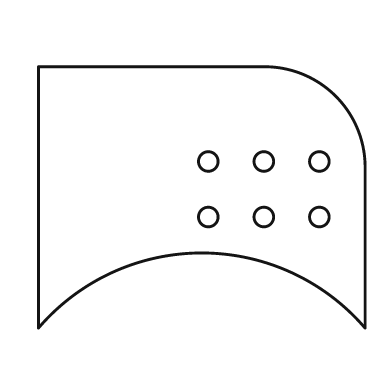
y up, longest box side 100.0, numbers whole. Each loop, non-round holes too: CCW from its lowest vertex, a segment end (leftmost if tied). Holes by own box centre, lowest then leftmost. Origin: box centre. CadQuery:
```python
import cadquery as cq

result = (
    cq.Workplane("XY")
    .moveTo(-50.0, -40.0)
    .threePointArc((0.0, -17.0), (50.0, -40.0))
    .lineTo(50.0, 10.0)
    .threePointArc((41.0, 31.0), (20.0, 40.0))
    .lineTo(-50.0, 40.0)
    .close()
    .moveTo(2.0, -6.0)
    .circle(3.0)
    .moveTo(19.0, -6.0)
    .circle(3.0)
    .moveTo(36.0, -6.0)
    .circle(3.0)
    .moveTo(2.0, 11.0)
    .circle(3.0)
    .moveTo(19.0, 11.0)
    .circle(3.0)
    .moveTo(36.0, 11.0)
    .circle(3.0)
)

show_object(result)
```